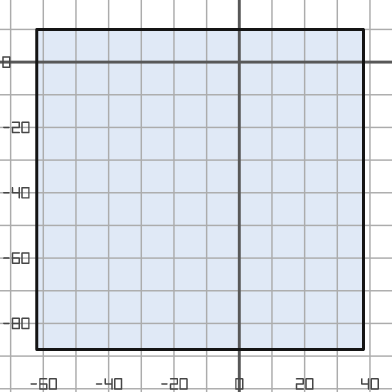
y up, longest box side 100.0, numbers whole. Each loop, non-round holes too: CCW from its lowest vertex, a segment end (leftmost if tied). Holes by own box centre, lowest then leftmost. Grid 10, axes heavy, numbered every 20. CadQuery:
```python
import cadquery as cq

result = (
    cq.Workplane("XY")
    .moveTo(-62.0, -88.0)
    .lineTo(38.0, -88.0)
    .lineTo(38.0, 10.0)
    .lineTo(-62.0, 10.0)
    .close()
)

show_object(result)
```